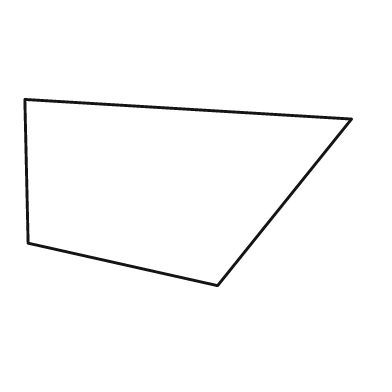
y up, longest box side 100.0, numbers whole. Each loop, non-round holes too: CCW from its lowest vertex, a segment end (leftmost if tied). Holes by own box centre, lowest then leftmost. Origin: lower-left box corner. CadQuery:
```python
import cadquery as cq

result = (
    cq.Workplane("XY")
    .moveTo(59.0, 0.0)
    .lineTo(100.0, 51.0)
    .lineTo(0.0, 57.0)
    .lineTo(1.0, 13.0)
    .close()
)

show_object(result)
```